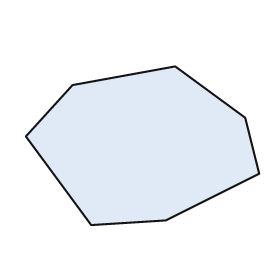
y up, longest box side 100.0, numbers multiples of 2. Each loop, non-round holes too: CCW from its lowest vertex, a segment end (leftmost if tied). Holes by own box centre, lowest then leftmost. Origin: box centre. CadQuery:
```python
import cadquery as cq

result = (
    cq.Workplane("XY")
    .moveTo(-22.0, -34.0)
    .lineTo(10.0, -32.0)
    .lineTo(50.0, -12.0)
    .lineTo(44.0, 12.0)
    .lineTo(14.0, 34.0)
    .lineTo(-30.0, 26.0)
    .lineTo(-50.0, 4.0)
    .close()
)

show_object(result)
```